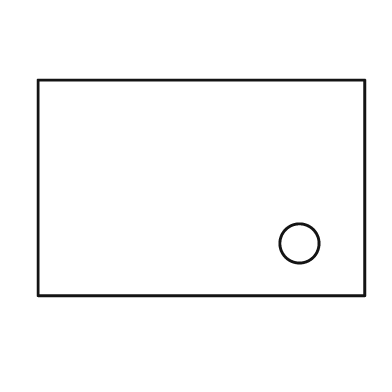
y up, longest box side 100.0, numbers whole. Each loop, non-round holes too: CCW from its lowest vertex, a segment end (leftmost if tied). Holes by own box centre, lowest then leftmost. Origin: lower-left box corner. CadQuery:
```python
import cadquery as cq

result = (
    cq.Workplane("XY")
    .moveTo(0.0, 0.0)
    .lineTo(100.0, 0.0)
    .lineTo(100.0, 66.0)
    .lineTo(0.0, 66.0)
    .close()
    .moveTo(80.0, 16.0)
    .circle(6.0)
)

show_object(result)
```